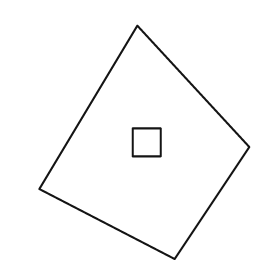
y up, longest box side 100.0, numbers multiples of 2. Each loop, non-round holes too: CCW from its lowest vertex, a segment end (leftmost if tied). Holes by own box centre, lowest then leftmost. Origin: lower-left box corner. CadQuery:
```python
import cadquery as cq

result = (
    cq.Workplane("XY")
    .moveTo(58.0, 0.0)
    .lineTo(90.0, 48.0)
    .lineTo(42.0, 100.0)
    .lineTo(0.0, 30.0)
    .close()
    .moveTo(40.0, 44.0)
    .lineTo(52.0, 44.0)
    .lineTo(52.0, 56.0)
    .lineTo(40.0, 56.0)
    .close()
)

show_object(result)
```